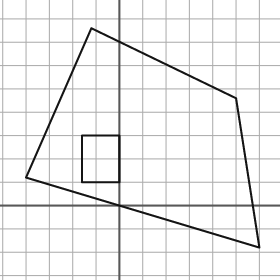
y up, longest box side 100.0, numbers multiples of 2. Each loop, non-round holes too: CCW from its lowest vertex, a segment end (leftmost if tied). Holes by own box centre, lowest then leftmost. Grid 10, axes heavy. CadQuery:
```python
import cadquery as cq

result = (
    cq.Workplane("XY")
    .moveTo(60.0, -18.0)
    .lineTo(50.0, 46.0)
    .lineTo(-12.0, 76.0)
    .lineTo(-40.0, 12.0)
    .close()
    .moveTo(-16.0, 10.0)
    .lineTo(0.0, 10.0)
    .lineTo(0.0, 30.0)
    .lineTo(-16.0, 30.0)
    .close()
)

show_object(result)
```